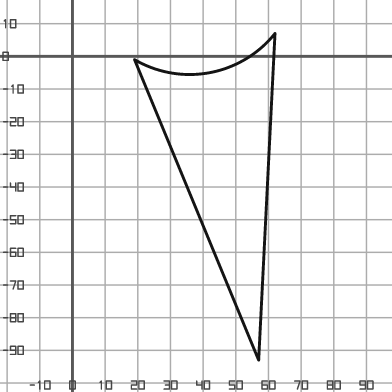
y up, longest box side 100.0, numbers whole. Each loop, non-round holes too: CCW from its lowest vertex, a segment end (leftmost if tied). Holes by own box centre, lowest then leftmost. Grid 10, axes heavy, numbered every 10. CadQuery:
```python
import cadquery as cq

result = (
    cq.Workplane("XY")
    .moveTo(57.0, -93.0)
    .lineTo(62.0, 7.0)
    .threePointArc((42.0, -5.0), (19.0, -1.0))
    .close()
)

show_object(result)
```